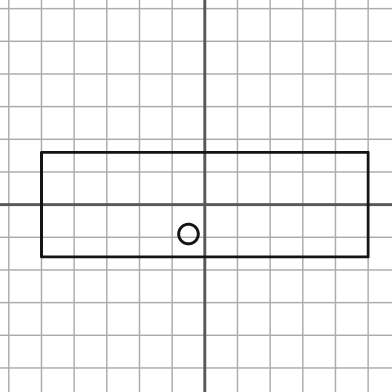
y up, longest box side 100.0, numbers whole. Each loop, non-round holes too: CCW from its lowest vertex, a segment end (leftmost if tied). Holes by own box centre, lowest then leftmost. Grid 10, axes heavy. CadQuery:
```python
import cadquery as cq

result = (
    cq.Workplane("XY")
    .moveTo(-50.0, -16.0)
    .lineTo(50.0, -16.0)
    .lineTo(50.0, 16.0)
    .lineTo(-50.0, 16.0)
    .close()
    .moveTo(-5.0, -9.0)
    .circle(3.0)
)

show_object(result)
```